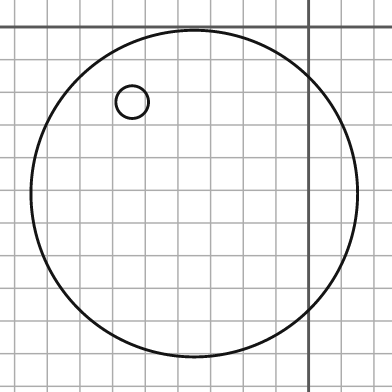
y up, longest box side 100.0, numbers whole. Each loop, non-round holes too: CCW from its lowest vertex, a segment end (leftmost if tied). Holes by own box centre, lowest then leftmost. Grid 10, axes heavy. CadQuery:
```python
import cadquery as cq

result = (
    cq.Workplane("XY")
    .moveTo(-35.0, -51.0)
    .circle(50.0)
    .moveTo(-54.0, -23.0)
    .circle(5.0)
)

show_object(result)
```